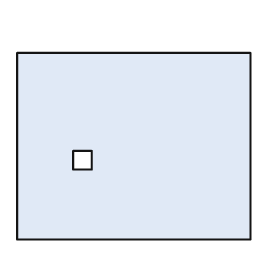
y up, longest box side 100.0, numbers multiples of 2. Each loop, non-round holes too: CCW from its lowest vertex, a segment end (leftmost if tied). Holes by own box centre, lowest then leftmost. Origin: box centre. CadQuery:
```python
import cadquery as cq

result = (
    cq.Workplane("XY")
    .moveTo(-50.0, -40.0)
    .lineTo(50.0, -40.0)
    .lineTo(50.0, 40.0)
    .lineTo(-50.0, 40.0)
    .close()
    .moveTo(-26.0, -10.0)
    .lineTo(-18.0, -10.0)
    .lineTo(-18.0, -2.0)
    .lineTo(-26.0, -2.0)
    .close()
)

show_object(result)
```